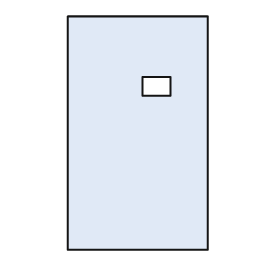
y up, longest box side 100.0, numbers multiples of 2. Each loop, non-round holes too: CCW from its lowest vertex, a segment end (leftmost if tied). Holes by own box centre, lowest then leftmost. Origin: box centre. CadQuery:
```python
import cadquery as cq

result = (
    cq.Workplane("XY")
    .moveTo(-30.0, -50.0)
    .lineTo(30.0, -50.0)
    .lineTo(30.0, 50.0)
    .lineTo(-30.0, 50.0)
    .close()
    .moveTo(2.0, 16.0)
    .lineTo(14.0, 16.0)
    .lineTo(14.0, 24.0)
    .lineTo(2.0, 24.0)
    .close()
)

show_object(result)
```